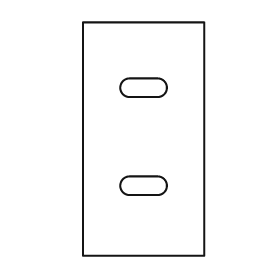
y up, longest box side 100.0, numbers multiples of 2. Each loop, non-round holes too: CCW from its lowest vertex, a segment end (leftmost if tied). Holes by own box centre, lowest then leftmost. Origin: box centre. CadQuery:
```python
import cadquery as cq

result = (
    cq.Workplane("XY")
    .moveTo(-26.0, -50.0)
    .lineTo(26.0, -50.0)
    .lineTo(26.0, 50.0)
    .lineTo(-26.0, 50.0)
    .close()
    .moveTo(-6.0, -24.0)
    .lineTo(6.0, -24.0)
    .threePointArc((10.0, -20.0), (6.0, -16.0))
    .lineTo(-6.0, -16.0)
    .threePointArc((-10.0, -20.0), (-6.0, -24.0))
    .close()
    .moveTo(-6.0, 18.0)
    .lineTo(6.0, 18.0)
    .threePointArc((10.0, 22.0), (6.0, 26.0))
    .lineTo(-6.0, 26.0)
    .threePointArc((-10.0, 22.0), (-6.0, 18.0))
    .close()
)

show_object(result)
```